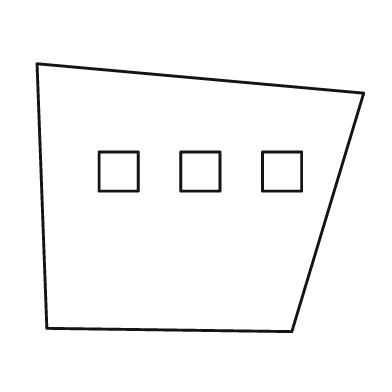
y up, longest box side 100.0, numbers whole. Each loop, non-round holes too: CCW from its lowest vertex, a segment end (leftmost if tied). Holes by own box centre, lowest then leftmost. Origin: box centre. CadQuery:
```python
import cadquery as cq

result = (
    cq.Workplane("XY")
    .moveTo(28.0, -41.0)
    .lineTo(50.0, 32.0)
    .lineTo(-50.0, 41.0)
    .lineTo(-47.0, -40.0)
    .close()
    .moveTo(-31.0, 2.0)
    .lineTo(-19.0, 2.0)
    .lineTo(-19.0, 14.0)
    .lineTo(-31.0, 14.0)
    .close()
    .moveTo(-6.0, 2.0)
    .lineTo(6.0, 2.0)
    .lineTo(6.0, 14.0)
    .lineTo(-6.0, 14.0)
    .close()
    .moveTo(19.0, 2.0)
    .lineTo(31.0, 2.0)
    .lineTo(31.0, 14.0)
    .lineTo(19.0, 14.0)
    .close()
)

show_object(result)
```